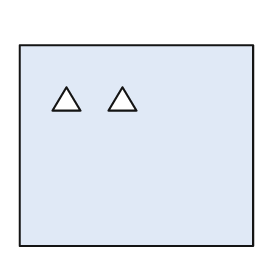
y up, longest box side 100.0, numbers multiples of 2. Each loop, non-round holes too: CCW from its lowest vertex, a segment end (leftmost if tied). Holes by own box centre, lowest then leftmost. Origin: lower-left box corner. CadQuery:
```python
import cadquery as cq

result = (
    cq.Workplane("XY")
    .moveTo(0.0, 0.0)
    .lineTo(100.0, 0.0)
    .lineTo(100.0, 86.0)
    .lineTo(0.0, 86.0)
    .close()
    .moveTo(14.0, 58.0)
    .lineTo(26.0, 58.0)
    .lineTo(20.0, 68.0)
    .close()
    .moveTo(38.0, 58.0)
    .lineTo(50.0, 58.0)
    .lineTo(44.0, 68.0)
    .close()
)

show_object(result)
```